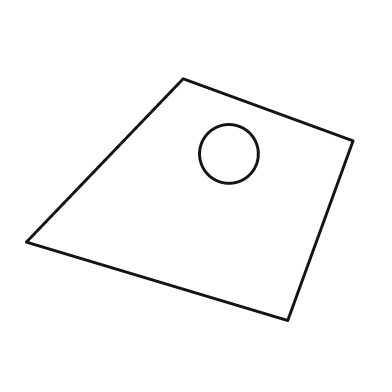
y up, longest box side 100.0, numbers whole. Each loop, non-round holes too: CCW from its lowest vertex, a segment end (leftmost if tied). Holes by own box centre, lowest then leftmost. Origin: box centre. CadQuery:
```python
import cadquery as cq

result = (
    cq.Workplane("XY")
    .moveTo(30.0, -37.0)
    .lineTo(50.0, 18.0)
    .lineTo(-2.0, 37.0)
    .lineTo(-50.0, -13.0)
    .close()
    .moveTo(12.0, 14.0)
    .circle(9.0)
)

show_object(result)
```